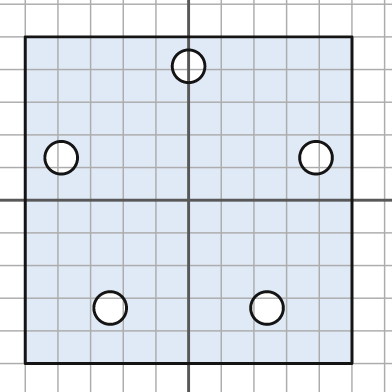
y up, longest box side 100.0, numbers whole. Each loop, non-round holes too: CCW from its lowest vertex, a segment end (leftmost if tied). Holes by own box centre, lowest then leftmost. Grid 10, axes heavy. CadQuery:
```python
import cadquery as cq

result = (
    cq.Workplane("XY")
    .moveTo(-50.0, -50.0)
    .lineTo(50.0, -50.0)
    .lineTo(50.0, 50.0)
    .lineTo(-50.0, 50.0)
    .close()
    .moveTo(-24.0, -33.0)
    .circle(5.0)
    .moveTo(24.0, -33.0)
    .circle(5.0)
    .moveTo(-39.0, 13.0)
    .circle(5.0)
    .moveTo(39.0, 13.0)
    .circle(5.0)
    .moveTo(0.0, 41.0)
    .circle(5.0)
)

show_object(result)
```